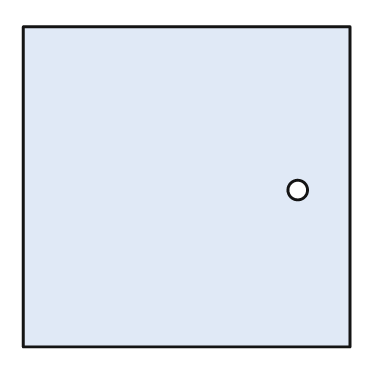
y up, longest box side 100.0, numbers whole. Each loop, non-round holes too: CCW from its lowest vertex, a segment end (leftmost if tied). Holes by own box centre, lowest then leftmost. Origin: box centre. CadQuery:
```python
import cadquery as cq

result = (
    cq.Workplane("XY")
    .moveTo(-50.0, -49.0)
    .lineTo(50.0, -49.0)
    .lineTo(50.0, 49.0)
    .lineTo(-50.0, 49.0)
    .close()
    .moveTo(34.0, -1.0)
    .circle(3.0)
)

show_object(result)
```